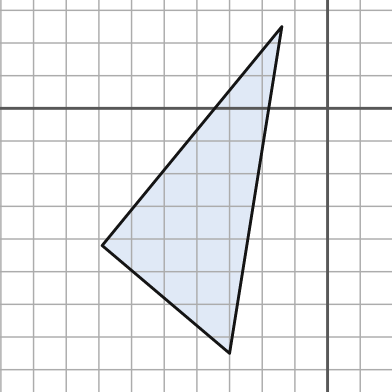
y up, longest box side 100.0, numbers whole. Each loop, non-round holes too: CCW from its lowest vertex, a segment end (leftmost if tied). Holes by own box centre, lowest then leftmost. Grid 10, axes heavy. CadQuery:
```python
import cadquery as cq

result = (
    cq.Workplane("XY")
    .moveTo(-30.0, -75.0)
    .lineTo(-14.0, 25.0)
    .lineTo(-69.0, -42.0)
    .close()
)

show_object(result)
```